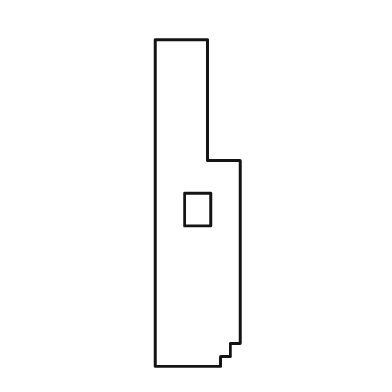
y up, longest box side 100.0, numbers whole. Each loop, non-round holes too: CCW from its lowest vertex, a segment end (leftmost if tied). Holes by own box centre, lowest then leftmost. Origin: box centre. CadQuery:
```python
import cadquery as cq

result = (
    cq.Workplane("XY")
    .moveTo(-13.0, -50.0)
    .lineTo(7.0, -50.0)
    .lineTo(7.0, -47.0)
    .lineTo(10.0, -47.0)
    .lineTo(10.0, -43.0)
    .lineTo(13.0, -43.0)
    .lineTo(13.0, 13.0)
    .lineTo(3.0, 13.0)
    .lineTo(3.0, 50.0)
    .lineTo(-13.0, 50.0)
    .close()
    .moveTo(-4.0, -7.0)
    .lineTo(4.0, -7.0)
    .lineTo(4.0, 3.0)
    .lineTo(-4.0, 3.0)
    .close()
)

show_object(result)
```